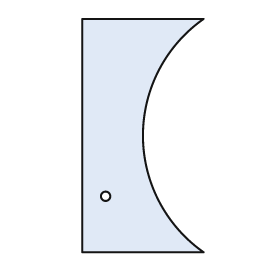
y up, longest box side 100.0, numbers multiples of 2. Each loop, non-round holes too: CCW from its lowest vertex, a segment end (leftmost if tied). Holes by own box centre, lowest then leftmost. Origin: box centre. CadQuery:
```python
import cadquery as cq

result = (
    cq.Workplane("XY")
    .moveTo(-26.0, -50.0)
    .lineTo(26.0, -50.0)
    .threePointArc((0.0, 0.0), (26.0, 50.0))
    .lineTo(-26.0, 50.0)
    .close()
    .moveTo(-16.0, -26.0)
    .circle(2.0)
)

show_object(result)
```